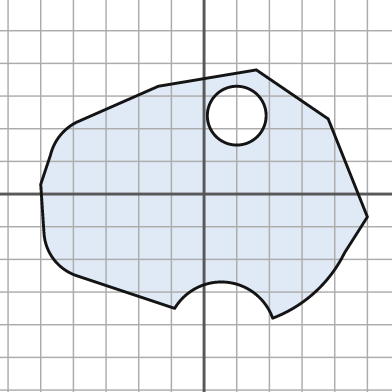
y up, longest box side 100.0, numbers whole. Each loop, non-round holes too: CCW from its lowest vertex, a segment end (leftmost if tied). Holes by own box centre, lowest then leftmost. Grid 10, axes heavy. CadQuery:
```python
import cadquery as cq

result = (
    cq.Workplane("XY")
    .moveTo(21.0, -38.0)
    .threePointArc((34.0, -30.0), (43.0, -18.0))
    .lineTo(50.0, -7.0)
    .lineTo(38.0, 23.0)
    .lineTo(16.0, 38.0)
    .lineTo(-14.0, 33.0)
    .lineTo(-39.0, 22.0)
    .threePointArc((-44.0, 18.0), (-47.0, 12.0))
    .lineTo(-50.0, 3.0)
    .lineTo(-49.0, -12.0)
    .threePointArc((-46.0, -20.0), (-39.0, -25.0))
    .lineTo(-9.0, -35.0)
    .threePointArc((7.0, -27.0), (21.0, -38.0))
    .close()
    .moveTo(10.0, 24.0)
    .circle(9.0)
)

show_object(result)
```